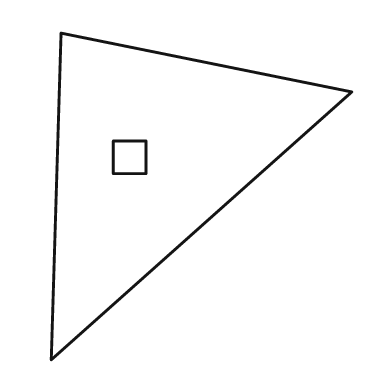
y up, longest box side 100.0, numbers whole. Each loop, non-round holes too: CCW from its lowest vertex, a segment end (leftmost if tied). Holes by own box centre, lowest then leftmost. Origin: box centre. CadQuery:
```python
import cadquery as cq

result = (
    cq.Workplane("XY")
    .moveTo(-46.0, -50.0)
    .lineTo(46.0, 32.0)
    .lineTo(-43.0, 50.0)
    .close()
    .moveTo(-27.0, 7.0)
    .lineTo(-17.0, 7.0)
    .lineTo(-17.0, 17.0)
    .lineTo(-27.0, 17.0)
    .close()
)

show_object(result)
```